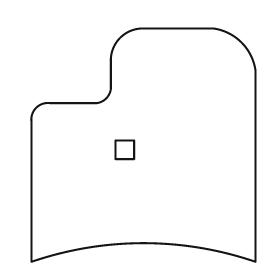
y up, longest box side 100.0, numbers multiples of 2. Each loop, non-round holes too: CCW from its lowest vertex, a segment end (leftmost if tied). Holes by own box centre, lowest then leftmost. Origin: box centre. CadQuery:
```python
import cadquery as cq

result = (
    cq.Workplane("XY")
    .moveTo(-48.0, -50.0)
    .threePointArc((0.0, -42.0), (48.0, -50.0))
    .lineTo(48.0, 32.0)
    .threePointArc((42.0, 44.0), (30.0, 50.0))
    .lineTo(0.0, 50.0)
    .threePointArc((-10.0, 46.0), (-14.0, 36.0))
    .lineTo(-14.0, 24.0)
    .threePointArc((-16.0, 20.0), (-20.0, 18.0))
    .lineTo(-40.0, 18.0)
    .threePointArc((-46.0, 16.0), (-48.0, 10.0))
    .close()
    .moveTo(-12.0, -6.0)
    .lineTo(-4.0, -6.0)
    .lineTo(-4.0, 2.0)
    .lineTo(-12.0, 2.0)
    .close()
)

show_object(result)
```